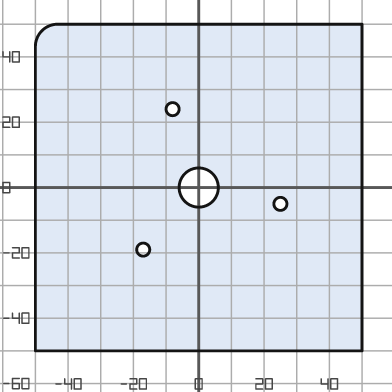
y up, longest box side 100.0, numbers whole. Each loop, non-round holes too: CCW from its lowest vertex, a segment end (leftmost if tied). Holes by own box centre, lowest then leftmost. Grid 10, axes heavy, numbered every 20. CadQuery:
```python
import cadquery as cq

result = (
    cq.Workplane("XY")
    .moveTo(-50.0, -50.0)
    .lineTo(50.0, -50.0)
    .lineTo(50.0, 50.0)
    .lineTo(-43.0, 50.0)
    .threePointArc((-48.0, 48.0), (-50.0, 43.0))
    .close()
    .moveTo(-17.0, -19.0)
    .circle(2.0)
    .moveTo(25.0, -5.0)
    .circle(2.0)
    .moveTo(0.0, 0.0)
    .circle(6.0)
    .moveTo(-8.0, 24.0)
    .circle(2.0)
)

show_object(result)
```